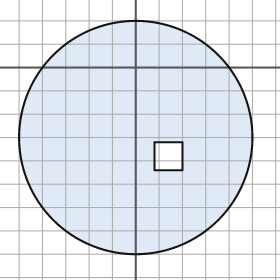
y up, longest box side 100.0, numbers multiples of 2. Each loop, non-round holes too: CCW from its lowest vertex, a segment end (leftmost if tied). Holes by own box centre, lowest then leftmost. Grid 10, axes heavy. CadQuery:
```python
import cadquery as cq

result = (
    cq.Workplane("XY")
    .moveTo(0.0, -30.0)
    .circle(50.0)
    .moveTo(8.0, -44.0)
    .lineTo(20.0, -44.0)
    .lineTo(20.0, -32.0)
    .lineTo(8.0, -32.0)
    .close()
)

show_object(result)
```